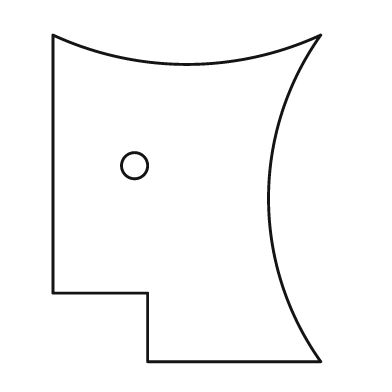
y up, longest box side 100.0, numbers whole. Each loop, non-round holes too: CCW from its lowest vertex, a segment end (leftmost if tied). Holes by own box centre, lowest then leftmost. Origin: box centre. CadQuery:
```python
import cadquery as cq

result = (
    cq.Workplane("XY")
    .moveTo(-12.0, -50.0)
    .lineTo(41.0, -50.0)
    .threePointArc((25.0, 0.0), (41.0, 50.0))
    .threePointArc((0.0, 41.0), (-41.0, 50.0))
    .lineTo(-41.0, -29.0)
    .lineTo(-12.0, -29.0)
    .close()
    .moveTo(-16.0, 10.0)
    .circle(4.0)
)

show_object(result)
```